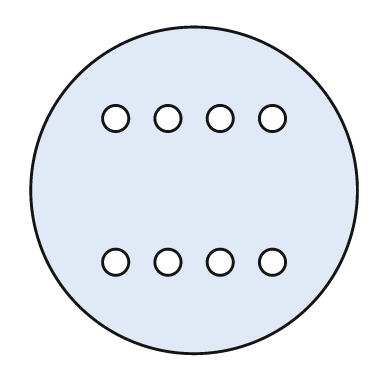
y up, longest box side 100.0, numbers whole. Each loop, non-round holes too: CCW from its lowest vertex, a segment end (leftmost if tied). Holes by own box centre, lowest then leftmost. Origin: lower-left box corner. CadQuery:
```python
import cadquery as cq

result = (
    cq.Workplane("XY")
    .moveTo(50.0, 50.0)
    .circle(50.0)
    .moveTo(26.0, 28.0)
    .circle(4.0)
    .moveTo(42.0, 28.0)
    .circle(4.0)
    .moveTo(58.0, 28.0)
    .circle(4.0)
    .moveTo(74.0, 28.0)
    .circle(4.0)
    .moveTo(26.0, 72.0)
    .circle(4.0)
    .moveTo(42.0, 72.0)
    .circle(4.0)
    .moveTo(58.0, 72.0)
    .circle(4.0)
    .moveTo(74.0, 72.0)
    .circle(4.0)
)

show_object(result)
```